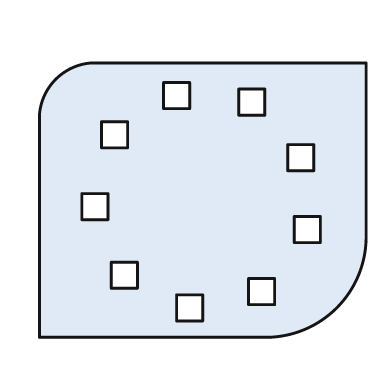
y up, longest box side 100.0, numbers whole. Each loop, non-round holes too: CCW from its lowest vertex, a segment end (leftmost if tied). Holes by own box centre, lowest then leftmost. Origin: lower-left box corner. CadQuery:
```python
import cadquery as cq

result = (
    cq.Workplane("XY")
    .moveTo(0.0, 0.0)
    .lineTo(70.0, 0.0)
    .threePointArc((91.0, 9.0), (100.0, 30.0))
    .lineTo(100.0, 84.0)
    .lineTo(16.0, 84.0)
    .threePointArc((5.0, 79.0), (0.0, 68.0))
    .close()
    .moveTo(42.0, 5.0)
    .lineTo(50.0, 5.0)
    .lineTo(50.0, 13.0)
    .lineTo(42.0, 13.0)
    .close()
    .moveTo(64.0, 10.0)
    .lineTo(72.0, 10.0)
    .lineTo(72.0, 18.0)
    .lineTo(64.0, 18.0)
    .close()
    .moveTo(22.0, 15.0)
    .lineTo(30.0, 15.0)
    .lineTo(30.0, 23.0)
    .lineTo(22.0, 23.0)
    .close()
    .moveTo(78.0, 29.0)
    .lineTo(86.0, 29.0)
    .lineTo(86.0, 37.0)
    .lineTo(78.0, 37.0)
    .close()
    .moveTo(13.0, 36.0)
    .lineTo(21.0, 36.0)
    .lineTo(21.0, 44.0)
    .lineTo(13.0, 44.0)
    .close()
    .moveTo(76.0, 51.0)
    .lineTo(84.0, 51.0)
    .lineTo(84.0, 59.0)
    .lineTo(76.0, 59.0)
    .close()
    .moveTo(19.0, 58.0)
    .lineTo(27.0, 58.0)
    .lineTo(27.0, 66.0)
    .lineTo(19.0, 66.0)
    .close()
    .moveTo(61.0, 68.0)
    .lineTo(69.0, 68.0)
    .lineTo(69.0, 76.0)
    .lineTo(61.0, 76.0)
    .close()
    .moveTo(38.0, 70.0)
    .lineTo(46.0, 70.0)
    .lineTo(46.0, 78.0)
    .lineTo(38.0, 78.0)
    .close()
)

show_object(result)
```